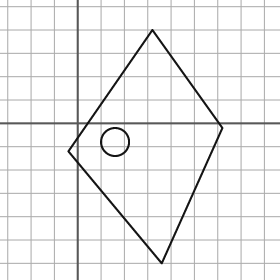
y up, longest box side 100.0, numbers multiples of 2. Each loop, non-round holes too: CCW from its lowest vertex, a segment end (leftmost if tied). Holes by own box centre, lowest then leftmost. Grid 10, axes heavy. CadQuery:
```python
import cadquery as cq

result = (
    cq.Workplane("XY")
    .moveTo(36.0, -60.0)
    .lineTo(62.0, -2.0)
    .lineTo(32.0, 40.0)
    .lineTo(-4.0, -12.0)
    .close()
    .moveTo(16.0, -8.0)
    .circle(6.0)
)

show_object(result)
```